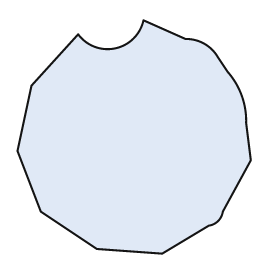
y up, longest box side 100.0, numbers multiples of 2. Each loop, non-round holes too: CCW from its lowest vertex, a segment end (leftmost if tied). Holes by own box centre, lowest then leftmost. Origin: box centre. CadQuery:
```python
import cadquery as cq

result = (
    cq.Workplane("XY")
    .moveTo(12.0, -50.0)
    .lineTo(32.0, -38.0)
    .threePointArc((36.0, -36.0), (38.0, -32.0))
    .lineTo(50.0, -10.0)
    .lineTo(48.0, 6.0)
    .threePointArc((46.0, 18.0), (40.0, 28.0))
    .lineTo(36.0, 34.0)
    .threePointArc((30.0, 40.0), (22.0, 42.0))
    .lineTo(4.0, 50.0)
    .threePointArc((-8.0, 38.0), (-24.0, 44.0))
    .lineTo(-44.0, 22.0)
    .lineTo(-50.0, -6.0)
    .lineTo(-40.0, -32.0)
    .lineTo(-16.0, -48.0)
    .close()
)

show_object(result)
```